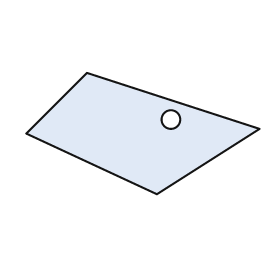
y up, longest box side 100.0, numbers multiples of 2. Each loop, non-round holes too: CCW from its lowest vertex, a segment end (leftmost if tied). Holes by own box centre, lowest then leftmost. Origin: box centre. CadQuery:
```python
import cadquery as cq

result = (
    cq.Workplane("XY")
    .moveTo(6.0, -26.0)
    .lineTo(50.0, 2.0)
    .lineTo(-24.0, 26.0)
    .lineTo(-50.0, 0.0)
    .close()
    .moveTo(12.0, 6.0)
    .circle(4.0)
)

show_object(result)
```